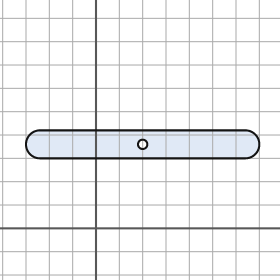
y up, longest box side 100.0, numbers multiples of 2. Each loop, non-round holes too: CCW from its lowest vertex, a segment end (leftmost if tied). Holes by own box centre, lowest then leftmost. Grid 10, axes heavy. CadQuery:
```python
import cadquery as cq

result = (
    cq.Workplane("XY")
    .moveTo(-24.0, 30.0)
    .lineTo(64.0, 30.0)
    .threePointArc((70.0, 36.0), (64.0, 42.0))
    .lineTo(-24.0, 42.0)
    .threePointArc((-30.0, 36.0), (-24.0, 30.0))
    .close()
    .moveTo(20.0, 36.0)
    .circle(2.0)
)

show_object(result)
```